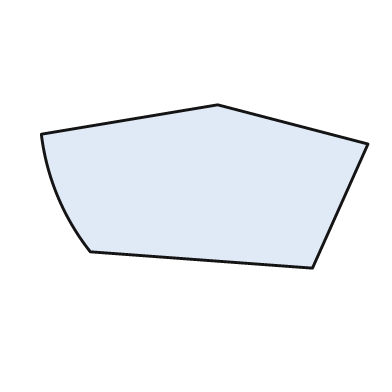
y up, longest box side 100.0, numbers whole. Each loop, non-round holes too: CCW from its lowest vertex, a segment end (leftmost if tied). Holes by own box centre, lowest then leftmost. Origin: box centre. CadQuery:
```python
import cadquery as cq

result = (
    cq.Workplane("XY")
    .moveTo(33.0, -25.0)
    .lineTo(50.0, 13.0)
    .lineTo(4.0, 25.0)
    .lineTo(-50.0, 16.0)
    .threePointArc((-45.0, -3.0), (-35.0, -20.0))
    .close()
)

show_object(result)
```